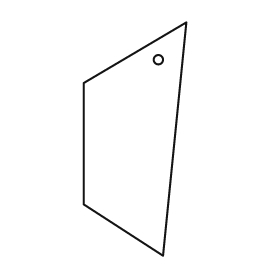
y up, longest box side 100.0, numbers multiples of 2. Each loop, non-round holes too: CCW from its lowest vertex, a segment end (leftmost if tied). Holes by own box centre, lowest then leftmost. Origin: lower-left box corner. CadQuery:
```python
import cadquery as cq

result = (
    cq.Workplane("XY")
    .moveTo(34.0, 0.0)
    .lineTo(44.0, 100.0)
    .lineTo(0.0, 74.0)
    .lineTo(0.0, 22.0)
    .close()
    .moveTo(32.0, 84.0)
    .circle(2.0)
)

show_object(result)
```